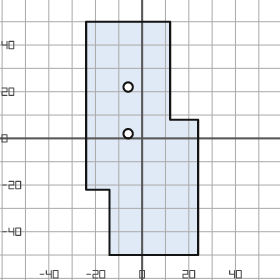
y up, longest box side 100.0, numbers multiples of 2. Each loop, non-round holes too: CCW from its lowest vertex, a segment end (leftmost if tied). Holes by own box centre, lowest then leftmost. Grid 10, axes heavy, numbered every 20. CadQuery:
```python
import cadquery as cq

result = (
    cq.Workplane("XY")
    .moveTo(-14.0, -50.0)
    .lineTo(24.0, -50.0)
    .lineTo(24.0, 8.0)
    .lineTo(12.0, 8.0)
    .lineTo(12.0, 50.0)
    .lineTo(-24.0, 50.0)
    .lineTo(-24.0, -22.0)
    .lineTo(-14.0, -22.0)
    .close()
    .moveTo(-6.0, 2.0)
    .circle(2.0)
    .moveTo(-6.0, 22.0)
    .circle(2.0)
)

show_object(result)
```